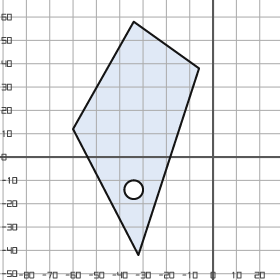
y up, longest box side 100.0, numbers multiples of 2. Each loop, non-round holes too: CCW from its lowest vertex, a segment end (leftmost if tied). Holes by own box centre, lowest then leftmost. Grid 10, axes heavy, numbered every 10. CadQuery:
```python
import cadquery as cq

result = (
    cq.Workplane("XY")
    .moveTo(-32.0, -42.0)
    .lineTo(-6.0, 38.0)
    .lineTo(-34.0, 58.0)
    .lineTo(-60.0, 12.0)
    .close()
    .moveTo(-34.0, -14.0)
    .circle(4.0)
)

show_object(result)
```